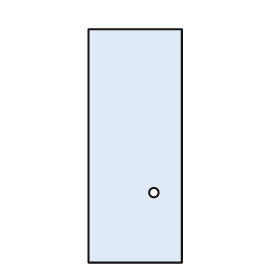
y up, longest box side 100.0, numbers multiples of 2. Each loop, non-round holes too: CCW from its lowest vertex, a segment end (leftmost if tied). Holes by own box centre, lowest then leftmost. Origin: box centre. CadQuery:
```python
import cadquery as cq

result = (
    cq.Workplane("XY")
    .moveTo(-20.0, -50.0)
    .lineTo(20.0, -50.0)
    .lineTo(20.0, 50.0)
    .lineTo(-20.0, 50.0)
    .close()
    .moveTo(8.0, -20.0)
    .circle(2.0)
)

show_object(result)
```